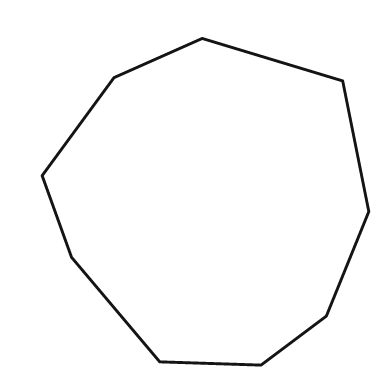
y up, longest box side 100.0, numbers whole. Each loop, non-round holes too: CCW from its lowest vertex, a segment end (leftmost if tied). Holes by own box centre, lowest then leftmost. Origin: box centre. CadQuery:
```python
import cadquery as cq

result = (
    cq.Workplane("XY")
    .moveTo(17.0, -50.0)
    .lineTo(37.0, -35.0)
    .lineTo(50.0, -3.0)
    .lineTo(42.0, 37.0)
    .lineTo(-1.0, 50.0)
    .lineTo(-28.0, 38.0)
    .lineTo(-50.0, 8.0)
    .lineTo(-41.0, -17.0)
    .lineTo(-14.0, -49.0)
    .close()
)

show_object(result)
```